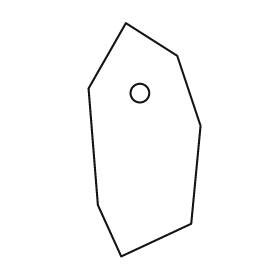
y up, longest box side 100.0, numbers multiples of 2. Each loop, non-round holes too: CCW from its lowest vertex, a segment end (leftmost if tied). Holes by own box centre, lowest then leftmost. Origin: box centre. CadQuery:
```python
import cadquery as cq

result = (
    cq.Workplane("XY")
    .moveTo(-10.0, -50.0)
    .lineTo(20.0, -36.0)
    .lineTo(24.0, 6.0)
    .lineTo(14.0, 36.0)
    .lineTo(-8.0, 50.0)
    .lineTo(-24.0, 22.0)
    .lineTo(-20.0, -28.0)
    .close()
    .moveTo(-2.0, 20.0)
    .circle(4.0)
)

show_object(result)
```